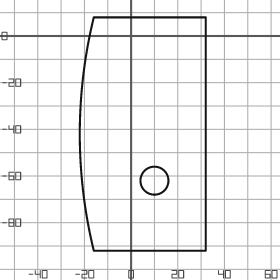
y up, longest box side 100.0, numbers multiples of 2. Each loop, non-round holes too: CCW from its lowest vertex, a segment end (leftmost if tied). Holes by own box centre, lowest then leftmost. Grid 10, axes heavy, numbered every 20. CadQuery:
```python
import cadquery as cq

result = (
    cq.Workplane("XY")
    .moveTo(-16.0, -92.0)
    .lineTo(32.0, -92.0)
    .lineTo(32.0, 8.0)
    .lineTo(-16.0, 8.0)
    .threePointArc((-22.0, -42.0), (-16.0, -92.0))
    .close()
    .moveTo(10.0, -62.0)
    .circle(6.0)
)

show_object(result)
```